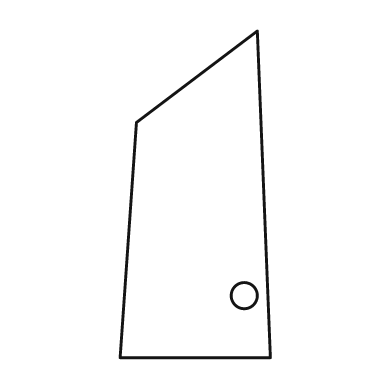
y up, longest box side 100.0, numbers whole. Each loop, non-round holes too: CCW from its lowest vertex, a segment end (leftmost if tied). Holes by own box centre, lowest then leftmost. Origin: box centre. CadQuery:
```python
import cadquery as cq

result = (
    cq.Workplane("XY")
    .moveTo(-23.0, -50.0)
    .lineTo(23.0, -50.0)
    .lineTo(19.0, 50.0)
    .lineTo(-18.0, 22.0)
    .close()
    .moveTo(15.0, -31.0)
    .circle(4.0)
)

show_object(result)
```